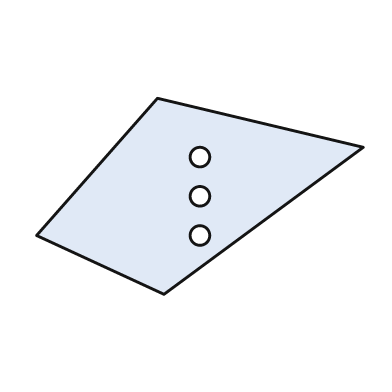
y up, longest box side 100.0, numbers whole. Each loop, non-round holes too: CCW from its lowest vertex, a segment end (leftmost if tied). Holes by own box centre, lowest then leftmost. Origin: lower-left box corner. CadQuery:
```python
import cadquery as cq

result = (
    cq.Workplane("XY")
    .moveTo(39.0, 0.0)
    .lineTo(100.0, 45.0)
    .lineTo(37.0, 60.0)
    .lineTo(0.0, 18.0)
    .close()
    .moveTo(50.0, 18.0)
    .circle(3.0)
    .moveTo(50.0, 30.0)
    .circle(3.0)
    .moveTo(50.0, 42.0)
    .circle(3.0)
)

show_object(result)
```